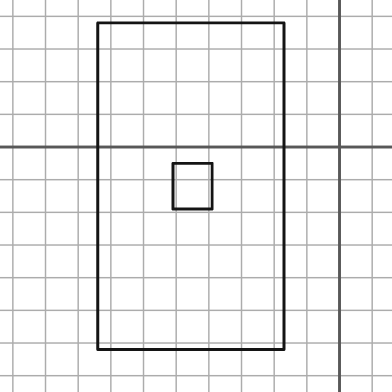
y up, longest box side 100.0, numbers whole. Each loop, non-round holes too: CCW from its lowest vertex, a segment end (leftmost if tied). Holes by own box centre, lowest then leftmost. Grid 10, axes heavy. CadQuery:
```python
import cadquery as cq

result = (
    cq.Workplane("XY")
    .moveTo(-74.0, -62.0)
    .lineTo(-17.0, -62.0)
    .lineTo(-17.0, 38.0)
    .lineTo(-74.0, 38.0)
    .close()
    .moveTo(-51.0, -19.0)
    .lineTo(-39.0, -19.0)
    .lineTo(-39.0, -5.0)
    .lineTo(-51.0, -5.0)
    .close()
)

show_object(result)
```